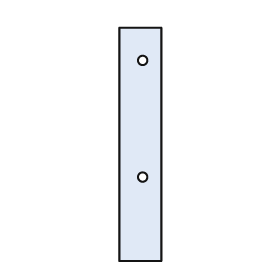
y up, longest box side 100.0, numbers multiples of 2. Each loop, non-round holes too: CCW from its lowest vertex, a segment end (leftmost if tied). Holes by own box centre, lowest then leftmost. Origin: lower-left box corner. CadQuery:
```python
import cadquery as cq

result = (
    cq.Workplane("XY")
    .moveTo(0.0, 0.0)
    .lineTo(18.0, 0.0)
    .lineTo(18.0, 100.0)
    .lineTo(0.0, 100.0)
    .close()
    .moveTo(10.0, 36.0)
    .circle(2.0)
    .moveTo(10.0, 86.0)
    .circle(2.0)
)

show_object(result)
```